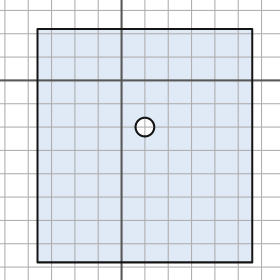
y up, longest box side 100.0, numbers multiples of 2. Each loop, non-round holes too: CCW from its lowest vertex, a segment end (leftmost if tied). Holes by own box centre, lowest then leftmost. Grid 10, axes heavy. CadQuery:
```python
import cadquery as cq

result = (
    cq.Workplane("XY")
    .moveTo(-36.0, -78.0)
    .lineTo(56.0, -78.0)
    .lineTo(56.0, 22.0)
    .lineTo(-36.0, 22.0)
    .close()
    .moveTo(10.0, -20.0)
    .circle(4.0)
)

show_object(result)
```